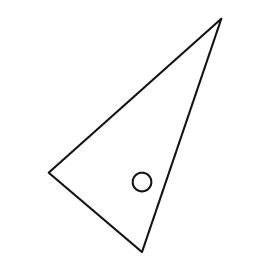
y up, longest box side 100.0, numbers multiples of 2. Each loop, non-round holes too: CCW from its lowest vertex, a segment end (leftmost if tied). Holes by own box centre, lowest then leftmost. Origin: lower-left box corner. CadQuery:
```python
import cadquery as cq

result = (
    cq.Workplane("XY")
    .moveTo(40.0, 0.0)
    .lineTo(74.0, 100.0)
    .lineTo(0.0, 34.0)
    .close()
    .moveTo(40.0, 30.0)
    .circle(4.0)
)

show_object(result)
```